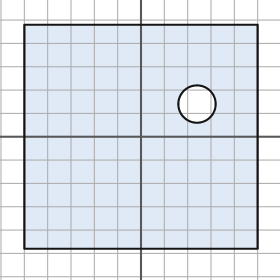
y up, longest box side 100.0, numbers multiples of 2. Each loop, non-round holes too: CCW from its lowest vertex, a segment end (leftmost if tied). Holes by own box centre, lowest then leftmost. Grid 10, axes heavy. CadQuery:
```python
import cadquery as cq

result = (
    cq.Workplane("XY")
    .moveTo(-50.0, -48.0)
    .lineTo(50.0, -48.0)
    .lineTo(50.0, 48.0)
    .lineTo(-50.0, 48.0)
    .close()
    .moveTo(24.0, 14.0)
    .circle(8.0)
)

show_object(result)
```